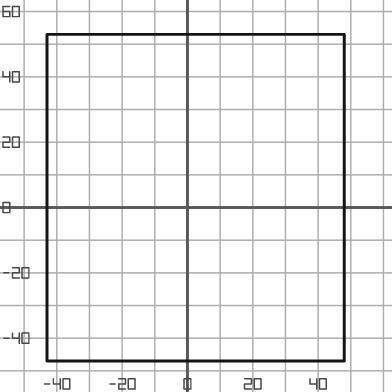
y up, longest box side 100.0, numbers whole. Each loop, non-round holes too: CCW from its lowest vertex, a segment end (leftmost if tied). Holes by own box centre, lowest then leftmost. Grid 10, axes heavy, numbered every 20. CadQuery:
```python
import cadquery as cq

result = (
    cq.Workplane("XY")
    .moveTo(-43.0, -47.0)
    .lineTo(48.0, -47.0)
    .lineTo(48.0, 53.0)
    .lineTo(-43.0, 53.0)
    .close()
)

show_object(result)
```